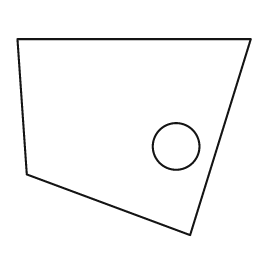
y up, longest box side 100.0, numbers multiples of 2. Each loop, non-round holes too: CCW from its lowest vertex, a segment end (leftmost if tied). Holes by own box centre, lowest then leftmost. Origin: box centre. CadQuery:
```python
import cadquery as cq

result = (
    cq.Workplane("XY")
    .moveTo(24.0, -42.0)
    .lineTo(50.0, 42.0)
    .lineTo(-50.0, 42.0)
    .lineTo(-46.0, -16.0)
    .close()
    .moveTo(18.0, -4.0)
    .circle(10.0)
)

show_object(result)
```